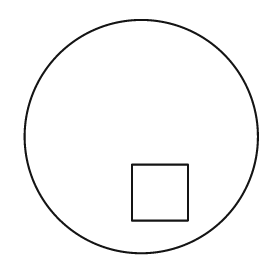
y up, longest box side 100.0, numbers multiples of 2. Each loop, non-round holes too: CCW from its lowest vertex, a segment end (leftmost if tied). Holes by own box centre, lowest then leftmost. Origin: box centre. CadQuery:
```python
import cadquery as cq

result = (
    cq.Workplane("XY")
    .moveTo(0.0, 0.0)
    .circle(50.0)
    .moveTo(-4.0, -36.0)
    .lineTo(20.0, -36.0)
    .lineTo(20.0, -12.0)
    .lineTo(-4.0, -12.0)
    .close()
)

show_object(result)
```